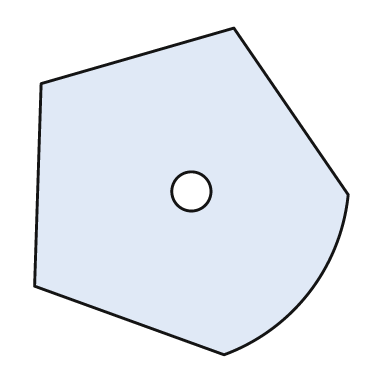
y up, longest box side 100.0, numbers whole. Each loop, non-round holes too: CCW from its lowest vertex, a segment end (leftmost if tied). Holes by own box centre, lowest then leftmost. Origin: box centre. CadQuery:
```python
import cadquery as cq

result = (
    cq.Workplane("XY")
    .moveTo(10.0, -50.0)
    .threePointArc((36.0, -31.0), (48.0, -1.0))
    .lineTo(13.0, 50.0)
    .lineTo(-46.0, 33.0)
    .lineTo(-48.0, -29.0)
    .close()
    .moveTo(0.0, 0.0)
    .circle(6.0)
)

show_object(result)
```